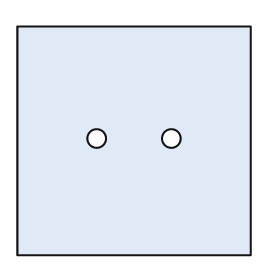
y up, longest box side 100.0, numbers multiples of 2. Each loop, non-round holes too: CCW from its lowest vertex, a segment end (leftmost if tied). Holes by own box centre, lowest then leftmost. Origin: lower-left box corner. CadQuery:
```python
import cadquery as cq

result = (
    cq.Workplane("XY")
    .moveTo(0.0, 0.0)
    .lineTo(100.0, 0.0)
    .lineTo(100.0, 98.0)
    .lineTo(0.0, 98.0)
    .close()
    .moveTo(34.0, 50.0)
    .circle(4.0)
    .moveTo(66.0, 50.0)
    .circle(4.0)
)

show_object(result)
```